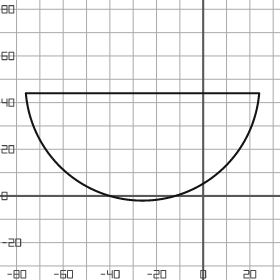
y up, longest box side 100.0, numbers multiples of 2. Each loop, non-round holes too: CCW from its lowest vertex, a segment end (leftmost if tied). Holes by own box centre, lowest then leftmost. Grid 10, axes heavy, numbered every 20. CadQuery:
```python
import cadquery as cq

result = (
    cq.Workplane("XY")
    .moveTo(-76.0, 44.0)
    .threePointArc((-26.0, -2.0), (24.0, 44.0))
    .close()
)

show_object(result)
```